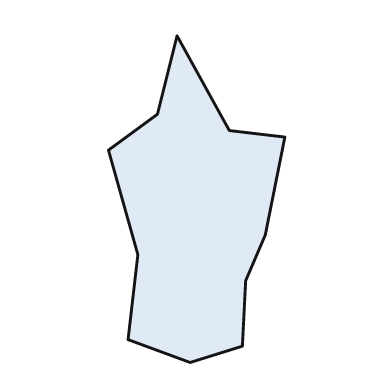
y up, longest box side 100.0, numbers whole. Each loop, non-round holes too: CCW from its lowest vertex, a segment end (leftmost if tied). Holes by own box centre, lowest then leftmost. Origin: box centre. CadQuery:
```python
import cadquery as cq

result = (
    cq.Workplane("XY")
    .moveTo(-2.0, -50.0)
    .lineTo(14.0, -45.0)
    .lineTo(15.0, -25.0)
    .lineTo(21.0, -11.0)
    .lineTo(27.0, 19.0)
    .lineTo(10.0, 21.0)
    .lineTo(-6.0, 50.0)
    .lineTo(-12.0, 26.0)
    .lineTo(-27.0, 15.0)
    .lineTo(-18.0, -17.0)
    .lineTo(-21.0, -43.0)
    .close()
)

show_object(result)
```